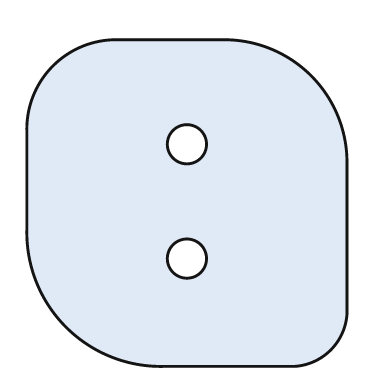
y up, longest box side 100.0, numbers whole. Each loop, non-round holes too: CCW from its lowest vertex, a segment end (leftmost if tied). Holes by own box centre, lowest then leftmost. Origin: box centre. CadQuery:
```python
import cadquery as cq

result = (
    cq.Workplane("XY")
    .moveTo(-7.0, -50.0)
    .lineTo(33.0, -50.0)
    .threePointArc((44.0, -45.0), (49.0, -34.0))
    .lineTo(49.0, 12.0)
    .threePointArc((38.0, 39.0), (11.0, 50.0))
    .lineTo(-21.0, 50.0)
    .threePointArc((-41.0, 42.0), (-49.0, 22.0))
    .lineTo(-49.0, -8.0)
    .threePointArc((-37.0, -38.0), (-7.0, -50.0))
    .close()
    .moveTo(0.0, -17.0)
    .circle(6.0)
    .moveTo(0.0, 18.0)
    .circle(6.0)
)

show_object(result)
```